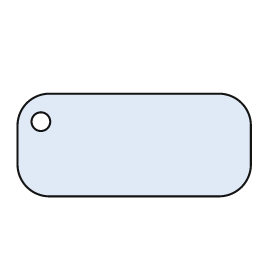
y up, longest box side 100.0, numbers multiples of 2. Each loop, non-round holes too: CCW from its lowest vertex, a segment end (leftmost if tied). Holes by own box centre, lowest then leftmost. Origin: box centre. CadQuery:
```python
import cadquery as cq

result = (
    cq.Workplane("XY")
    .moveTo(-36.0, -22.0)
    .lineTo(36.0, -22.0)
    .threePointArc((46.0, -18.0), (50.0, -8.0))
    .lineTo(50.0, 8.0)
    .threePointArc((46.0, 18.0), (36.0, 22.0))
    .lineTo(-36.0, 22.0)
    .threePointArc((-46.0, 18.0), (-50.0, 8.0))
    .lineTo(-50.0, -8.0)
    .threePointArc((-46.0, -18.0), (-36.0, -22.0))
    .close()
    .moveTo(-40.0, 10.0)
    .circle(4.0)
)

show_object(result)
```